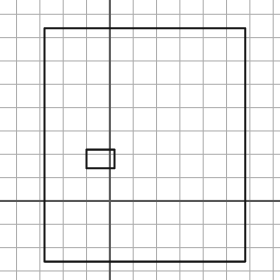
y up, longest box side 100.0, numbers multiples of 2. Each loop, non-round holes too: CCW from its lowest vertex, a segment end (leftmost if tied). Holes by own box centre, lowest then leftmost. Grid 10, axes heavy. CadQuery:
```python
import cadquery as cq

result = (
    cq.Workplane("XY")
    .moveTo(-28.0, -26.0)
    .lineTo(58.0, -26.0)
    .lineTo(58.0, 74.0)
    .lineTo(-28.0, 74.0)
    .close()
    .moveTo(-10.0, 14.0)
    .lineTo(2.0, 14.0)
    .lineTo(2.0, 22.0)
    .lineTo(-10.0, 22.0)
    .close()
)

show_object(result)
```